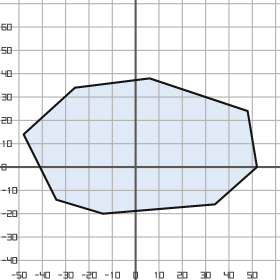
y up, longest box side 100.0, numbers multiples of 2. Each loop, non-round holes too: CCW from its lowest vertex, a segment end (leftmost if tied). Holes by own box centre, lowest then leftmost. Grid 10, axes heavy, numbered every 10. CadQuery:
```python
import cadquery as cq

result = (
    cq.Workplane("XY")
    .moveTo(-14.0, -20.0)
    .lineTo(34.0, -16.0)
    .lineTo(52.0, 0.0)
    .lineTo(48.0, 24.0)
    .lineTo(6.0, 38.0)
    .lineTo(-26.0, 34.0)
    .lineTo(-48.0, 14.0)
    .lineTo(-34.0, -14.0)
    .close()
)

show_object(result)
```